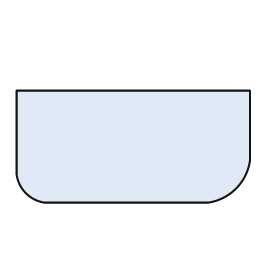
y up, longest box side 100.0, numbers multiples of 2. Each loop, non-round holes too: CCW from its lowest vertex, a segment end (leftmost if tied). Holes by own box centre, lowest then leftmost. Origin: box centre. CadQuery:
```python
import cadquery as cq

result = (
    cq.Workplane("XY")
    .moveTo(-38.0, -24.0)
    .lineTo(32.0, -24.0)
    .threePointArc((44.0, -18.0), (50.0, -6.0))
    .lineTo(50.0, 24.0)
    .lineTo(-50.0, 24.0)
    .lineTo(-50.0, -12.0)
    .threePointArc((-46.0, -20.0), (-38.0, -24.0))
    .close()
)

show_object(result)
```